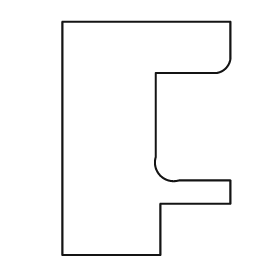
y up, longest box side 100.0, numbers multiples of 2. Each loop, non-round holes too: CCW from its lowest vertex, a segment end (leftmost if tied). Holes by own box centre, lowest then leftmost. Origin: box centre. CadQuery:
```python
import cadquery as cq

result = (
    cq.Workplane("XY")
    .moveTo(-36.0, -50.0)
    .lineTo(6.0, -50.0)
    .lineTo(6.0, -28.0)
    .lineTo(36.0, -28.0)
    .lineTo(36.0, -18.0)
    .lineTo(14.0, -18.0)
    .threePointArc((6.0, -16.0), (4.0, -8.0))
    .lineTo(4.0, 28.0)
    .lineTo(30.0, 28.0)
    .threePointArc((34.0, 30.0), (36.0, 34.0))
    .lineTo(36.0, 50.0)
    .lineTo(-36.0, 50.0)
    .close()
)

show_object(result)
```